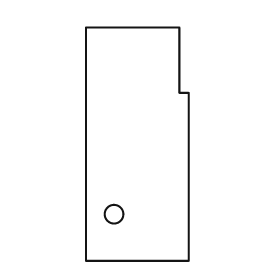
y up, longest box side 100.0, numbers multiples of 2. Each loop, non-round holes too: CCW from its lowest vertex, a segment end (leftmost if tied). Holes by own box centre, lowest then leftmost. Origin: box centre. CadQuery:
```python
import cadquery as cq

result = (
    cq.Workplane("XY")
    .moveTo(-22.0, -50.0)
    .lineTo(22.0, -50.0)
    .lineTo(22.0, 22.0)
    .lineTo(18.0, 22.0)
    .lineTo(18.0, 50.0)
    .lineTo(-22.0, 50.0)
    .close()
    .moveTo(-10.0, -30.0)
    .circle(4.0)
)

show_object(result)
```